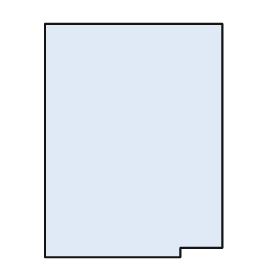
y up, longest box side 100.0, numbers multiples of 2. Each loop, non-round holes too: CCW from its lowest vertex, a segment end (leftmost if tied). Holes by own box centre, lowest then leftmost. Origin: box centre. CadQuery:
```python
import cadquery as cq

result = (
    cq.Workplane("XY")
    .moveTo(-38.0, -50.0)
    .lineTo(20.0, -50.0)
    .lineTo(20.0, -46.0)
    .lineTo(38.0, -46.0)
    .lineTo(38.0, 50.0)
    .lineTo(-38.0, 50.0)
    .close()
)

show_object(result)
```